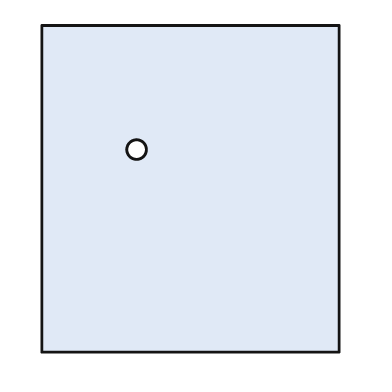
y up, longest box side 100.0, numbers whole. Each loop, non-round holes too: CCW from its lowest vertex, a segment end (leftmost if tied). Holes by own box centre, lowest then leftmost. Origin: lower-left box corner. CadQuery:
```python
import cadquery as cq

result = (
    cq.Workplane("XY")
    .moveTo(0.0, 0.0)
    .lineTo(91.0, 0.0)
    .lineTo(91.0, 100.0)
    .lineTo(0.0, 100.0)
    .close()
    .moveTo(29.0, 62.0)
    .circle(3.0)
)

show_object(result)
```